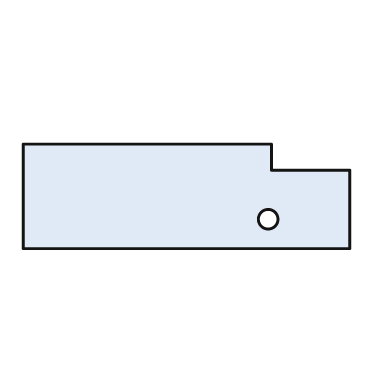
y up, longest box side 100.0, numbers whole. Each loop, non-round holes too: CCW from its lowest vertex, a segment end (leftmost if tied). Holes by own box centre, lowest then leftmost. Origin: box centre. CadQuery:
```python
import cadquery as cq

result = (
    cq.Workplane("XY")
    .moveTo(-50.0, -16.0)
    .lineTo(50.0, -16.0)
    .lineTo(50.0, 8.0)
    .lineTo(26.0, 8.0)
    .lineTo(26.0, 16.0)
    .lineTo(-50.0, 16.0)
    .close()
    .moveTo(25.0, -7.0)
    .circle(3.0)
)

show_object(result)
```